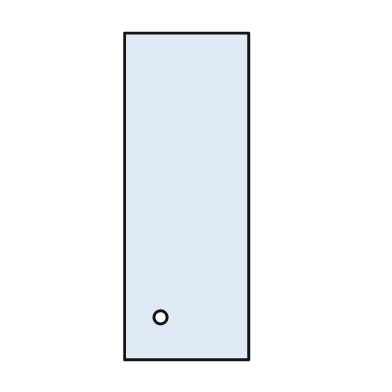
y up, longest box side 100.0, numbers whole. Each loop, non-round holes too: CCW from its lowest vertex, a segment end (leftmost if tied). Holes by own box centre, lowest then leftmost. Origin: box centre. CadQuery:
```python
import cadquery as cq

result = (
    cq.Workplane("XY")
    .moveTo(-19.0, -50.0)
    .lineTo(19.0, -50.0)
    .lineTo(19.0, 50.0)
    .lineTo(-19.0, 50.0)
    .close()
    .moveTo(-8.0, -37.0)
    .circle(2.0)
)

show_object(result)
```